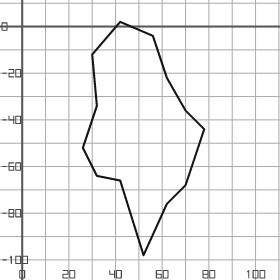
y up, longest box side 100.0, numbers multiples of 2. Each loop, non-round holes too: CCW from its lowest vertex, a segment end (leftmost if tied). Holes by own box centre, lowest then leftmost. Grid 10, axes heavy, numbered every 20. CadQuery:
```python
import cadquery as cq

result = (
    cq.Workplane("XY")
    .moveTo(52.0, -98.0)
    .lineTo(62.0, -76.0)
    .lineTo(70.0, -68.0)
    .lineTo(78.0, -44.0)
    .lineTo(70.0, -36.0)
    .lineTo(62.0, -22.0)
    .lineTo(56.0, -4.0)
    .lineTo(42.0, 2.0)
    .lineTo(30.0, -12.0)
    .lineTo(32.0, -34.0)
    .lineTo(26.0, -52.0)
    .lineTo(32.0, -64.0)
    .lineTo(42.0, -66.0)
    .close()
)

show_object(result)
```